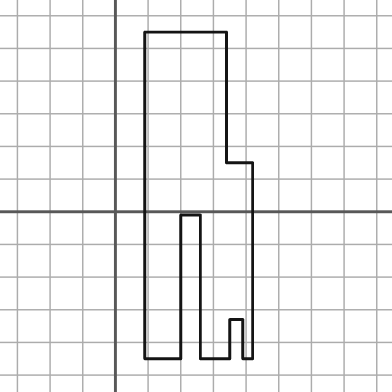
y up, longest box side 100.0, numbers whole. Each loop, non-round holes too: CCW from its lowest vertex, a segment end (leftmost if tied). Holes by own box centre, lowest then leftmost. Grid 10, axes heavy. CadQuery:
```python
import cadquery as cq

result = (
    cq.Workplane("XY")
    .moveTo(9.0, -45.0)
    .lineTo(20.0, -45.0)
    .lineTo(20.0, -1.0)
    .lineTo(26.0, -1.0)
    .lineTo(26.0, -45.0)
    .lineTo(35.0, -45.0)
    .lineTo(35.0, -33.0)
    .lineTo(39.0, -33.0)
    .lineTo(39.0, -45.0)
    .lineTo(42.0, -45.0)
    .lineTo(42.0, 15.0)
    .lineTo(34.0, 15.0)
    .lineTo(34.0, 55.0)
    .lineTo(9.0, 55.0)
    .close()
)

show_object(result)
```